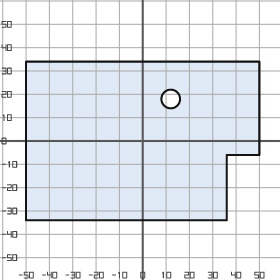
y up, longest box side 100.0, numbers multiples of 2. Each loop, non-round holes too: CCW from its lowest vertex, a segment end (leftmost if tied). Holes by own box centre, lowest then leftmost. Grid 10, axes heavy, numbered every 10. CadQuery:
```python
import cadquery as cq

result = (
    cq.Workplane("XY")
    .moveTo(-50.0, -34.0)
    .lineTo(36.0, -34.0)
    .lineTo(36.0, -6.0)
    .lineTo(50.0, -6.0)
    .lineTo(50.0, 34.0)
    .lineTo(-50.0, 34.0)
    .close()
    .moveTo(12.0, 18.0)
    .circle(4.0)
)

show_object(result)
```